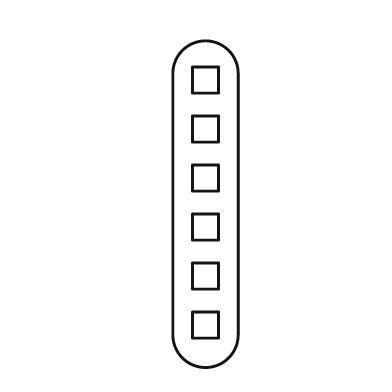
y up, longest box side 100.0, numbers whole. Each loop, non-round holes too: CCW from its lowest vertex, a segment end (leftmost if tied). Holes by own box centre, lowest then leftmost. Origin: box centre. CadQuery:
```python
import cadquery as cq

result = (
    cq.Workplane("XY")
    .moveTo(-10.0, -40.0)
    .threePointArc((0.0, -50.0), (10.0, -40.0))
    .lineTo(10.0, 40.0)
    .threePointArc((0.0, 50.0), (-10.0, 40.0))
    .close()
    .moveTo(-4.0, -41.0)
    .lineTo(4.0, -41.0)
    .lineTo(4.0, -33.0)
    .lineTo(-4.0, -33.0)
    .close()
    .moveTo(-4.0, -26.0)
    .lineTo(4.0, -26.0)
    .lineTo(4.0, -18.0)
    .lineTo(-4.0, -18.0)
    .close()
    .moveTo(-4.0, -11.0)
    .lineTo(4.0, -11.0)
    .lineTo(4.0, -3.0)
    .lineTo(-4.0, -3.0)
    .close()
    .moveTo(-4.0, 4.0)
    .lineTo(4.0, 4.0)
    .lineTo(4.0, 12.0)
    .lineTo(-4.0, 12.0)
    .close()
    .moveTo(-4.0, 19.0)
    .lineTo(4.0, 19.0)
    .lineTo(4.0, 27.0)
    .lineTo(-4.0, 27.0)
    .close()
    .moveTo(-4.0, 34.0)
    .lineTo(4.0, 34.0)
    .lineTo(4.0, 42.0)
    .lineTo(-4.0, 42.0)
    .close()
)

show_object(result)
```